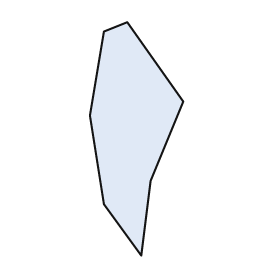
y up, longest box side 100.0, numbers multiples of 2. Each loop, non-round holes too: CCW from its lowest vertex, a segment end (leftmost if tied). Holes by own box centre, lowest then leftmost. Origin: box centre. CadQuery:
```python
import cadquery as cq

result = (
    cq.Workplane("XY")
    .moveTo(2.0, -50.0)
    .lineTo(6.0, -18.0)
    .lineTo(20.0, 16.0)
    .lineTo(-4.0, 50.0)
    .lineTo(-14.0, 46.0)
    .lineTo(-20.0, 10.0)
    .lineTo(-14.0, -28.0)
    .close()
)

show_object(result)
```